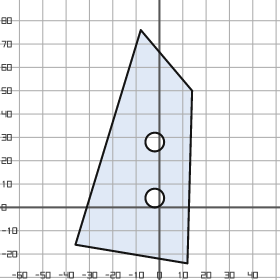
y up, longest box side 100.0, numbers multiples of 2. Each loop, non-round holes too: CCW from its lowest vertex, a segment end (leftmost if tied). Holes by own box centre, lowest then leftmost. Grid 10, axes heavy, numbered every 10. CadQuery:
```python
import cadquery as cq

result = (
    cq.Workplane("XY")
    .moveTo(12.0, -24.0)
    .lineTo(14.0, 50.0)
    .lineTo(-8.0, 76.0)
    .lineTo(-36.0, -16.0)
    .close()
    .moveTo(-2.0, 4.0)
    .circle(4.0)
    .moveTo(-2.0, 28.0)
    .circle(4.0)
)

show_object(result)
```